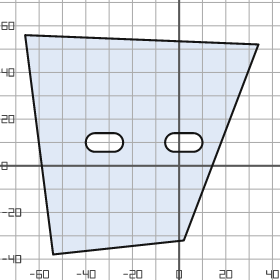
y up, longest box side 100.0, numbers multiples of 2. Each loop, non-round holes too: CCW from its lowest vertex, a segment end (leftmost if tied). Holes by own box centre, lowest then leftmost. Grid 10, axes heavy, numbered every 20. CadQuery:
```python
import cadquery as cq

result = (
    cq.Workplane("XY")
    .moveTo(-54.0, -38.0)
    .lineTo(2.0, -32.0)
    .lineTo(34.0, 52.0)
    .lineTo(-66.0, 56.0)
    .close()
    .moveTo(-36.0, 6.0)
    .lineTo(-28.0, 6.0)
    .threePointArc((-24.0, 10.0), (-28.0, 14.0))
    .lineTo(-36.0, 14.0)
    .threePointArc((-40.0, 10.0), (-36.0, 6.0))
    .close()
    .moveTo(-2.0, 6.0)
    .lineTo(6.0, 6.0)
    .threePointArc((10.0, 10.0), (6.0, 14.0))
    .lineTo(-2.0, 14.0)
    .threePointArc((-6.0, 10.0), (-2.0, 6.0))
    .close()
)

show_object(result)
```